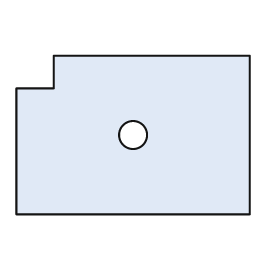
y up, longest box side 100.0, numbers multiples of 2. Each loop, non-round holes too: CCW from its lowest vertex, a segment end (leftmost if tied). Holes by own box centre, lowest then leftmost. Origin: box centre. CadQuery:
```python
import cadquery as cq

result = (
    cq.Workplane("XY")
    .moveTo(-50.0, -34.0)
    .lineTo(50.0, -34.0)
    .lineTo(50.0, 34.0)
    .lineTo(-34.0, 34.0)
    .lineTo(-34.0, 20.0)
    .lineTo(-50.0, 20.0)
    .close()
    .moveTo(0.0, 0.0)
    .circle(6.0)
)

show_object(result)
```